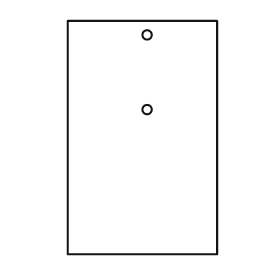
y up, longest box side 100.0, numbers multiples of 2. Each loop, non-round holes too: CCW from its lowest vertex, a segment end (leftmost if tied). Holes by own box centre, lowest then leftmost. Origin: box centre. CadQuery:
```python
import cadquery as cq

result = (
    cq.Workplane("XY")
    .moveTo(-32.0, -50.0)
    .lineTo(32.0, -50.0)
    .lineTo(32.0, 50.0)
    .lineTo(-32.0, 50.0)
    .close()
    .moveTo(2.0, 12.0)
    .circle(2.0)
    .moveTo(2.0, 44.0)
    .circle(2.0)
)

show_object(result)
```